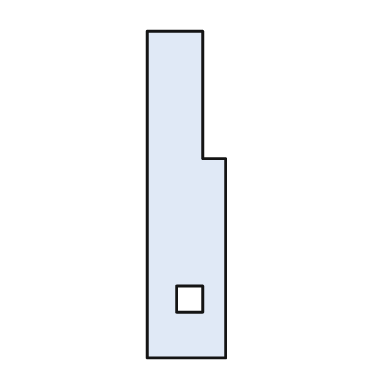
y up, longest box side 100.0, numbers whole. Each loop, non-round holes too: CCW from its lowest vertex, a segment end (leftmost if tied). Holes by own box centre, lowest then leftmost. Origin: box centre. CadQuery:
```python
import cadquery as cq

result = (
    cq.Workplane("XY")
    .moveTo(-12.0, -50.0)
    .lineTo(12.0, -50.0)
    .lineTo(12.0, 11.0)
    .lineTo(5.0, 11.0)
    .lineTo(5.0, 50.0)
    .lineTo(-12.0, 50.0)
    .close()
    .moveTo(-3.0, -36.0)
    .lineTo(5.0, -36.0)
    .lineTo(5.0, -28.0)
    .lineTo(-3.0, -28.0)
    .close()
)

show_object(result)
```